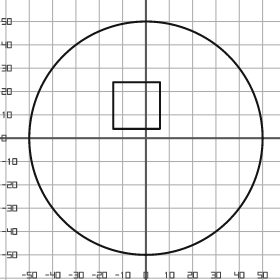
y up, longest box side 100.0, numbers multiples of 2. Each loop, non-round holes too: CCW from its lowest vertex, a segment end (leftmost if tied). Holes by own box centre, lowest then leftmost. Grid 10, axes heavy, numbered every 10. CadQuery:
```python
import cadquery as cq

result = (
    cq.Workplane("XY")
    .moveTo(0.0, 0.0)
    .circle(50.0)
    .moveTo(-14.0, 4.0)
    .lineTo(6.0, 4.0)
    .lineTo(6.0, 24.0)
    .lineTo(-14.0, 24.0)
    .close()
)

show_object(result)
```